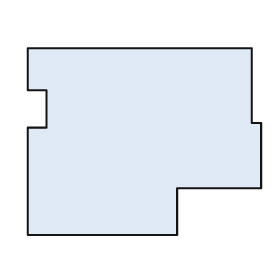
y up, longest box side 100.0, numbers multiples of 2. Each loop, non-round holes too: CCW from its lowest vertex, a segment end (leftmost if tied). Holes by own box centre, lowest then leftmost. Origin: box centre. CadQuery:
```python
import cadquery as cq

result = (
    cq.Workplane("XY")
    .moveTo(-50.0, -40.0)
    .lineTo(14.0, -40.0)
    .lineTo(14.0, -20.0)
    .lineTo(50.0, -20.0)
    .lineTo(50.0, 8.0)
    .lineTo(46.0, 8.0)
    .lineTo(46.0, 40.0)
    .lineTo(-50.0, 40.0)
    .lineTo(-50.0, 22.0)
    .lineTo(-42.0, 22.0)
    .lineTo(-42.0, 6.0)
    .lineTo(-50.0, 6.0)
    .close()
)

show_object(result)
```